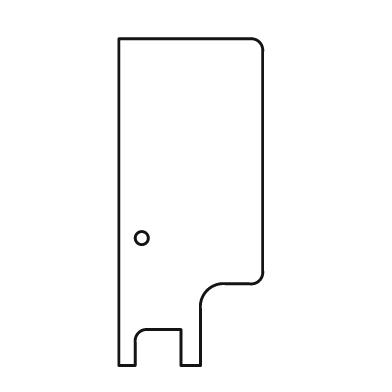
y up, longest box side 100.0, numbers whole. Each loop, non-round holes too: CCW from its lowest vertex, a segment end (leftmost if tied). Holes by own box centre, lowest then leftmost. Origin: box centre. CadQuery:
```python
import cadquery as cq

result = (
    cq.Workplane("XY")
    .moveTo(-22.0, -50.0)
    .lineTo(-17.0, -50.0)
    .lineTo(-17.0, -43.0)
    .threePointArc((-16.0, -40.0), (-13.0, -39.0))
    .lineTo(-3.0, -39.0)
    .lineTo(-3.0, -50.0)
    .lineTo(3.0, -50.0)
    .lineTo(3.0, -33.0)
    .threePointArc((5.0, -27.0), (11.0, -25.0))
    .lineTo(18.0, -25.0)
    .threePointArc((21.0, -24.0), (22.0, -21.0))
    .lineTo(22.0, 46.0)
    .threePointArc((21.0, 49.0), (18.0, 50.0))
    .lineTo(-22.0, 50.0)
    .close()
    .moveTo(-15.0, -11.0)
    .circle(2.0)
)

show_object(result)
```